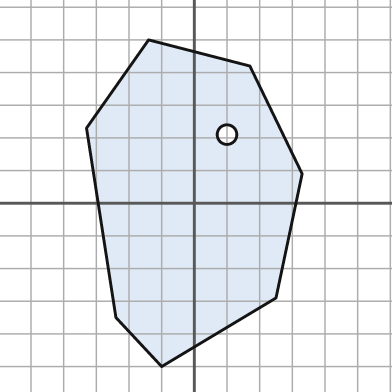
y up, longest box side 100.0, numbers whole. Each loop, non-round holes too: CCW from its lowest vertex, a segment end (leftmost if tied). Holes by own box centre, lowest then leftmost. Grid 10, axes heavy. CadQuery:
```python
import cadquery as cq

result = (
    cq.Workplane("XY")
    .moveTo(-10.0, -50.0)
    .lineTo(25.0, -29.0)
    .lineTo(33.0, 9.0)
    .lineTo(17.0, 42.0)
    .lineTo(-14.0, 50.0)
    .lineTo(-33.0, 23.0)
    .lineTo(-24.0, -35.0)
    .close()
    .moveTo(10.0, 21.0)
    .circle(3.0)
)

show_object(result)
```